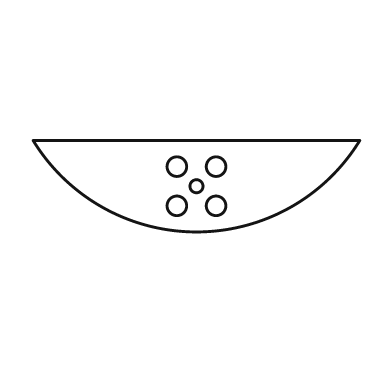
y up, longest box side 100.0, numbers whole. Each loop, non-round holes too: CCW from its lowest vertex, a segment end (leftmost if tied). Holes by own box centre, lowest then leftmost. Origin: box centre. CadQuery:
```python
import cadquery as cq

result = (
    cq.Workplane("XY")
    .moveTo(-50.0, 14.0)
    .threePointArc((0.0, -14.0), (50.0, 14.0))
    .close()
    .moveTo(-6.0, -6.0)
    .circle(3.0)
    .moveTo(6.0, -6.0)
    .circle(3.0)
    .moveTo(0.0, 0.0)
    .circle(2.0)
    .moveTo(-6.0, 6.0)
    .circle(3.0)
    .moveTo(6.0, 6.0)
    .circle(3.0)
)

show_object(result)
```